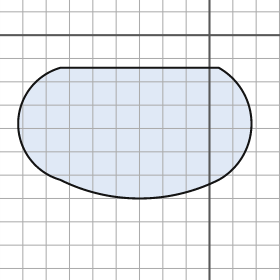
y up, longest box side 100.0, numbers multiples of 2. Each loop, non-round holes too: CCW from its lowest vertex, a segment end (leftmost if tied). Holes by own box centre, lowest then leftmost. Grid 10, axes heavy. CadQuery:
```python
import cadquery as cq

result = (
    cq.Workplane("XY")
    .moveTo(-64.0, -62.0)
    .threePointArc((-30.0, -70.0), (4.0, -62.0))
    .threePointArc((18.0, -38.0), (4.0, -14.0))
    .lineTo(-64.0, -14.0)
    .threePointArc((-82.0, -38.0), (-64.0, -62.0))
    .close()
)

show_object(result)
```